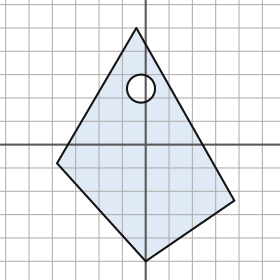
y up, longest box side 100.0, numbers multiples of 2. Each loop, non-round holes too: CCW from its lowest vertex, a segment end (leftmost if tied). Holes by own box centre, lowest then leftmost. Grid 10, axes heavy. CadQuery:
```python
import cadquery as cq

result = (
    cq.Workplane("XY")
    .moveTo(0.0, -50.0)
    .lineTo(38.0, -24.0)
    .lineTo(-4.0, 50.0)
    .lineTo(-38.0, -8.0)
    .close()
    .moveTo(-2.0, 24.0)
    .circle(6.0)
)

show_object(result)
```